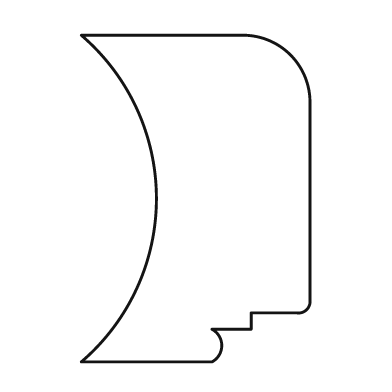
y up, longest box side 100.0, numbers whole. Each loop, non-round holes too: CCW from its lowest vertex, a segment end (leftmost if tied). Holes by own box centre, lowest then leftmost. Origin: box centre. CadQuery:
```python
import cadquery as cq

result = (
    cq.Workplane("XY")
    .moveTo(-35.0, -50.0)
    .lineTo(5.0, -50.0)
    .threePointArc((8.0, -45.0), (5.0, -40.0))
    .lineTo(17.0, -40.0)
    .lineTo(17.0, -35.0)
    .lineTo(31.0, -35.0)
    .threePointArc((34.0, -34.0), (35.0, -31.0))
    .lineTo(35.0, 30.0)
    .threePointArc((29.0, 44.0), (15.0, 50.0))
    .lineTo(-35.0, 50.0)
    .threePointArc((-12.0, 0.0), (-35.0, -50.0))
    .close()
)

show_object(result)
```